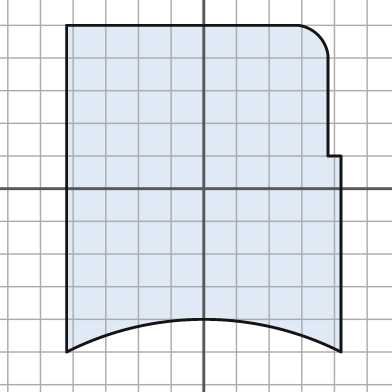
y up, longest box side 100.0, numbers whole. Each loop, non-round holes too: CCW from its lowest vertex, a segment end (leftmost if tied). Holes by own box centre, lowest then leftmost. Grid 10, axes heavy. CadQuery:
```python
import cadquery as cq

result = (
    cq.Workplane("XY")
    .moveTo(-42.0, -50.0)
    .threePointArc((0.0, -40.0), (42.0, -50.0))
    .lineTo(42.0, 10.0)
    .lineTo(38.0, 10.0)
    .lineTo(38.0, 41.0)
    .threePointArc((35.0, 47.0), (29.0, 50.0))
    .lineTo(-42.0, 50.0)
    .close()
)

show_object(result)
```